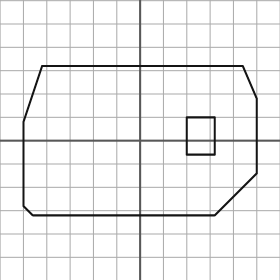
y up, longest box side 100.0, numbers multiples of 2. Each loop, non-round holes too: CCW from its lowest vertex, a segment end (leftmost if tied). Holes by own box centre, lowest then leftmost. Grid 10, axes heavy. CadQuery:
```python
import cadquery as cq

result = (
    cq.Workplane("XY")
    .moveTo(-46.0, -32.0)
    .lineTo(32.0, -32.0)
    .lineTo(50.0, -14.0)
    .lineTo(50.0, 18.0)
    .lineTo(44.0, 32.0)
    .lineTo(-42.0, 32.0)
    .lineTo(-50.0, 8.0)
    .lineTo(-50.0, -28.0)
    .close()
    .moveTo(20.0, -6.0)
    .lineTo(32.0, -6.0)
    .lineTo(32.0, 10.0)
    .lineTo(20.0, 10.0)
    .close()
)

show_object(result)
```